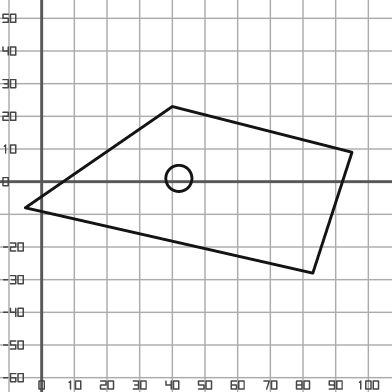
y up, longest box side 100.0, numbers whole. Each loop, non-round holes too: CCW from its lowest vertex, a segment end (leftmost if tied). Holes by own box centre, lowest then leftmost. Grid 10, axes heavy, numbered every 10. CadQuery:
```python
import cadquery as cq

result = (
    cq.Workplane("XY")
    .moveTo(83.0, -28.0)
    .lineTo(95.0, 9.0)
    .lineTo(40.0, 23.0)
    .lineTo(-5.0, -8.0)
    .close()
    .moveTo(42.0, 1.0)
    .circle(4.0)
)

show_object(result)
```